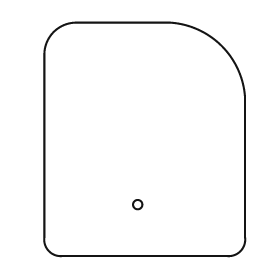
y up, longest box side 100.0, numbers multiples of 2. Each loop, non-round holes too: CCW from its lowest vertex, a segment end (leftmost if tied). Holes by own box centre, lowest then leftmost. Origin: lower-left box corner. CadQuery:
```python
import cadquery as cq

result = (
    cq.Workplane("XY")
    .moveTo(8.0, 0.0)
    .lineTo(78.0, 0.0)
    .threePointArc((84.0, 2.0), (86.0, 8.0))
    .lineTo(86.0, 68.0)
    .threePointArc((76.0, 90.0), (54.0, 100.0))
    .lineTo(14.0, 100.0)
    .threePointArc((4.0, 96.0), (0.0, 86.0))
    .lineTo(0.0, 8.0)
    .threePointArc((2.0, 2.0), (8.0, 0.0))
    .close()
    .moveTo(40.0, 22.0)
    .circle(2.0)
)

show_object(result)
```